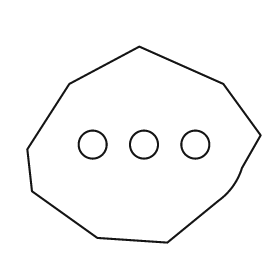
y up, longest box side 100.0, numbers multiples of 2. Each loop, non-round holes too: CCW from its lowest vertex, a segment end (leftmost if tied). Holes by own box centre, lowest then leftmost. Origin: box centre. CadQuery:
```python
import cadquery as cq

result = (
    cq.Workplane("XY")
    .moveTo(10.0, -42.0)
    .lineTo(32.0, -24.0)
    .threePointArc((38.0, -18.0), (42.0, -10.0))
    .lineTo(50.0, 4.0)
    .lineTo(34.0, 26.0)
    .lineTo(-2.0, 42.0)
    .lineTo(-32.0, 26.0)
    .lineTo(-50.0, -2.0)
    .lineTo(-48.0, -20.0)
    .lineTo(-20.0, -40.0)
    .close()
    .moveTo(-22.0, 0.0)
    .circle(6.0)
    .moveTo(0.0, 0.0)
    .circle(6.0)
    .moveTo(22.0, 0.0)
    .circle(6.0)
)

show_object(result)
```